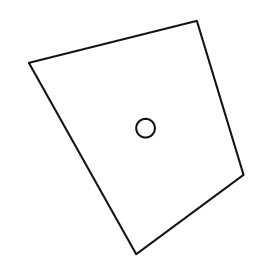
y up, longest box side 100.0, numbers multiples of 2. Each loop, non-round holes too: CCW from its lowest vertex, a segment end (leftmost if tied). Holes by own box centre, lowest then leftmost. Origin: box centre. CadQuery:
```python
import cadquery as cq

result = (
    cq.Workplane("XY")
    .moveTo(0.0, -50.0)
    .lineTo(46.0, -16.0)
    .lineTo(26.0, 50.0)
    .lineTo(-46.0, 32.0)
    .close()
    .moveTo(4.0, 4.0)
    .circle(4.0)
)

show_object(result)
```